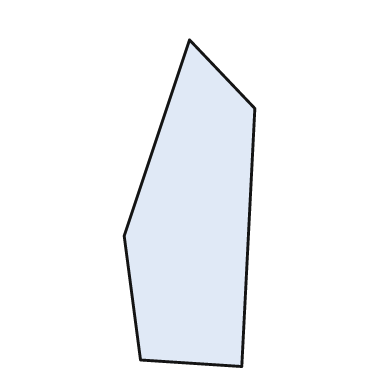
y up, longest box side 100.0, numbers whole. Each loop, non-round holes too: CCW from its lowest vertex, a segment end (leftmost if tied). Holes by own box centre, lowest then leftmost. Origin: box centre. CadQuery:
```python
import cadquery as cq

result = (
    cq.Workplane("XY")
    .moveTo(16.0, -50.0)
    .lineTo(20.0, 29.0)
    .lineTo(0.0, 50.0)
    .lineTo(-20.0, -10.0)
    .lineTo(-15.0, -48.0)
    .close()
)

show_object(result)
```